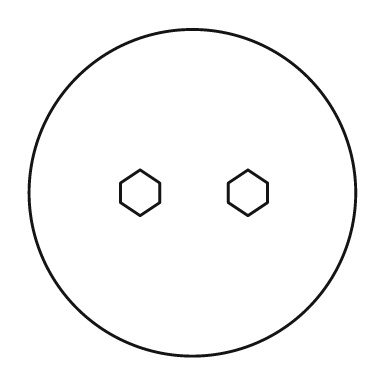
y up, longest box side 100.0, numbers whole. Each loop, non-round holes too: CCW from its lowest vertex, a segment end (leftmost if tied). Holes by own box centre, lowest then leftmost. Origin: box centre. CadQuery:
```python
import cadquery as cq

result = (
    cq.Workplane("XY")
    .moveTo(0.0, 0.0)
    .circle(50.0)
    .moveTo(-16.0, -7.0)
    .lineTo(-10.0, -3.0)
    .lineTo(-10.0, 3.0)
    .lineTo(-16.0, 7.0)
    .lineTo(-22.0, 3.0)
    .lineTo(-22.0, -3.0)
    .close()
    .moveTo(17.0, -7.0)
    .lineTo(23.0, -3.0)
    .lineTo(23.0, 3.0)
    .lineTo(17.0, 7.0)
    .lineTo(11.0, 3.0)
    .lineTo(11.0, -3.0)
    .close()
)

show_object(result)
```